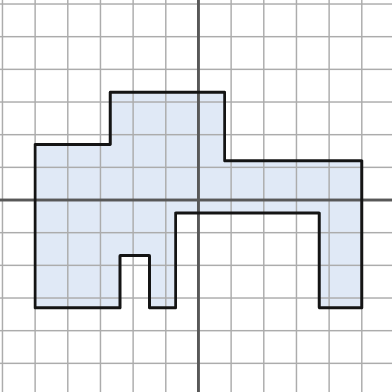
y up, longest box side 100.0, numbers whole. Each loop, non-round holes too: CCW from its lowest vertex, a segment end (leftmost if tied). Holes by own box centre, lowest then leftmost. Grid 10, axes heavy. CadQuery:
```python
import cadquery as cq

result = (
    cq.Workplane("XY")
    .moveTo(-50.0, -33.0)
    .lineTo(-24.0, -33.0)
    .lineTo(-24.0, -17.0)
    .lineTo(-15.0, -17.0)
    .lineTo(-15.0, -33.0)
    .lineTo(-7.0, -33.0)
    .lineTo(-7.0, -4.0)
    .lineTo(37.0, -4.0)
    .lineTo(37.0, -33.0)
    .lineTo(50.0, -33.0)
    .lineTo(50.0, 12.0)
    .lineTo(8.0, 12.0)
    .lineTo(8.0, 33.0)
    .lineTo(-27.0, 33.0)
    .lineTo(-27.0, 17.0)
    .lineTo(-50.0, 17.0)
    .close()
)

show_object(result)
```